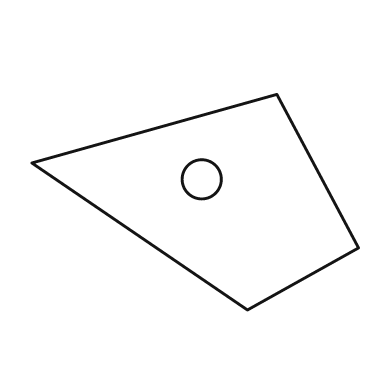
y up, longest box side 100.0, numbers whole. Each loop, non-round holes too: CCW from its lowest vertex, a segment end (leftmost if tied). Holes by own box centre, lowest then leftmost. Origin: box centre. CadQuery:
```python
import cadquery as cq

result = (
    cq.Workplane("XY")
    .moveTo(16.0, -33.0)
    .lineTo(50.0, -14.0)
    .lineTo(25.0, 33.0)
    .lineTo(-50.0, 12.0)
    .close()
    .moveTo(2.0, 7.0)
    .circle(6.0)
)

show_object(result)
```